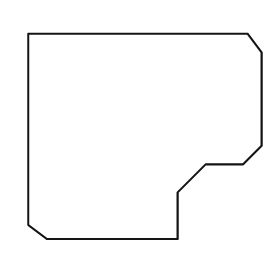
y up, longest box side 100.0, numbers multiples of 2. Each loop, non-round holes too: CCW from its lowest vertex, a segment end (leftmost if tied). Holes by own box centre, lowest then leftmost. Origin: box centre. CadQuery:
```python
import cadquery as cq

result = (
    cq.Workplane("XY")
    .moveTo(-42.0, -44.0)
    .lineTo(14.0, -44.0)
    .lineTo(14.0, -24.0)
    .lineTo(26.0, -12.0)
    .lineTo(42.0, -12.0)
    .lineTo(50.0, -4.0)
    .lineTo(50.0, 36.0)
    .lineTo(44.0, 44.0)
    .lineTo(-50.0, 44.0)
    .lineTo(-50.0, -38.0)
    .close()
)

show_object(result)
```